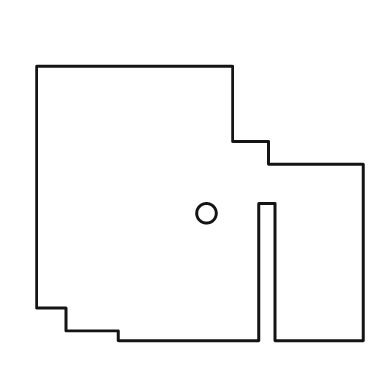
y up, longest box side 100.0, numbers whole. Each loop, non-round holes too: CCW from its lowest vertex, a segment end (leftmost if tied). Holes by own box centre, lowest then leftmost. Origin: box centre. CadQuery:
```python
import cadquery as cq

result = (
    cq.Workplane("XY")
    .moveTo(-25.0, -42.0)
    .lineTo(18.0, -42.0)
    .lineTo(18.0, 0.0)
    .lineTo(23.0, 0.0)
    .lineTo(23.0, -42.0)
    .lineTo(50.0, -42.0)
    .lineTo(50.0, 12.0)
    .lineTo(21.0, 12.0)
    .lineTo(21.0, 19.0)
    .lineTo(10.0, 19.0)
    .lineTo(10.0, 42.0)
    .lineTo(-50.0, 42.0)
    .lineTo(-50.0, -32.0)
    .lineTo(-41.0, -32.0)
    .lineTo(-41.0, -39.0)
    .lineTo(-25.0, -39.0)
    .close()
    .moveTo(2.0, -3.0)
    .circle(3.0)
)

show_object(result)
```